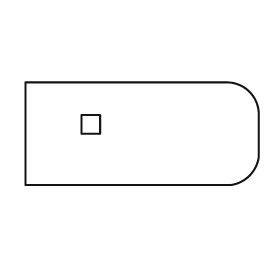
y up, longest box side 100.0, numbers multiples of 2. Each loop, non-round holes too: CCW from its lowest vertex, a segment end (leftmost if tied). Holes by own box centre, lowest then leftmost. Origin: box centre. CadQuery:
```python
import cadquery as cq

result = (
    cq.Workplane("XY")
    .moveTo(-50.0, -22.0)
    .lineTo(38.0, -22.0)
    .threePointArc((46.0, -18.0), (50.0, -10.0))
    .lineTo(50.0, 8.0)
    .threePointArc((46.0, 18.0), (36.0, 22.0))
    .lineTo(-50.0, 22.0)
    .close()
    .moveTo(-26.0, 0.0)
    .lineTo(-18.0, 0.0)
    .lineTo(-18.0, 8.0)
    .lineTo(-26.0, 8.0)
    .close()
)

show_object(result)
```